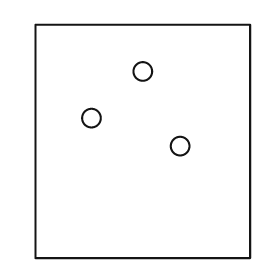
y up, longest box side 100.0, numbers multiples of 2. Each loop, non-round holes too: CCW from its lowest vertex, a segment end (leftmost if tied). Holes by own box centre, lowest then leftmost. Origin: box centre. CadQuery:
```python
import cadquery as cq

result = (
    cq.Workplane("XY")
    .moveTo(-46.0, -50.0)
    .lineTo(46.0, -50.0)
    .lineTo(46.0, 50.0)
    .lineTo(-46.0, 50.0)
    .close()
    .moveTo(16.0, -2.0)
    .circle(4.0)
    .moveTo(-22.0, 10.0)
    .circle(4.0)
    .moveTo(0.0, 30.0)
    .circle(4.0)
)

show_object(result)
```